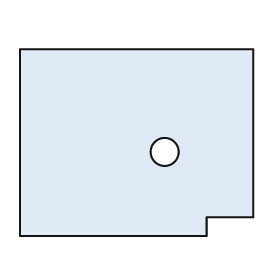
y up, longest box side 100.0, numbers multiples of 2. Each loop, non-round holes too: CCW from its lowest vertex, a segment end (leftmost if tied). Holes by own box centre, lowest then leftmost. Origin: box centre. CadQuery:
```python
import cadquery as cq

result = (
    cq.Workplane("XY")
    .moveTo(-50.0, -40.0)
    .lineTo(30.0, -40.0)
    .lineTo(30.0, -32.0)
    .lineTo(50.0, -32.0)
    .lineTo(50.0, 40.0)
    .lineTo(-50.0, 40.0)
    .close()
    .moveTo(12.0, -4.0)
    .circle(6.0)
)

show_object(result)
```